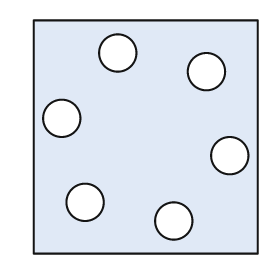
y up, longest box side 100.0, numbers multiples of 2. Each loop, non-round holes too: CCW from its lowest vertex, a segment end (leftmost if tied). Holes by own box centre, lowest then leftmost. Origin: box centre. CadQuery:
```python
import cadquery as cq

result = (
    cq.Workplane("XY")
    .moveTo(-48.0, -50.0)
    .lineTo(48.0, -50.0)
    .lineTo(48.0, 50.0)
    .lineTo(-48.0, 50.0)
    .close()
    .moveTo(12.0, -36.0)
    .circle(8.0)
    .moveTo(-26.0, -28.0)
    .circle(8.0)
    .moveTo(36.0, -8.0)
    .circle(8.0)
    .moveTo(-36.0, 8.0)
    .circle(8.0)
    .moveTo(26.0, 28.0)
    .circle(8.0)
    .moveTo(-12.0, 36.0)
    .circle(8.0)
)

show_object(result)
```